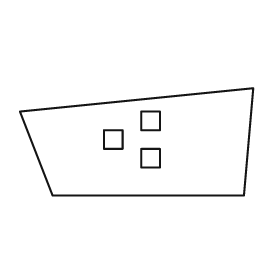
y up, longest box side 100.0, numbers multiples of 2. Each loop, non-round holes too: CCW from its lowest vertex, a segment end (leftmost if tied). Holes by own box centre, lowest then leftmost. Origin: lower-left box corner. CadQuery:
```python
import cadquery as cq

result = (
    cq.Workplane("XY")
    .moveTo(14.0, 0.0)
    .lineTo(96.0, 0.0)
    .lineTo(100.0, 46.0)
    .lineTo(0.0, 36.0)
    .close()
    .moveTo(52.0, 12.0)
    .lineTo(60.0, 12.0)
    .lineTo(60.0, 20.0)
    .lineTo(52.0, 20.0)
    .close()
    .moveTo(36.0, 20.0)
    .lineTo(44.0, 20.0)
    .lineTo(44.0, 28.0)
    .lineTo(36.0, 28.0)
    .close()
    .moveTo(52.0, 28.0)
    .lineTo(60.0, 28.0)
    .lineTo(60.0, 36.0)
    .lineTo(52.0, 36.0)
    .close()
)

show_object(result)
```